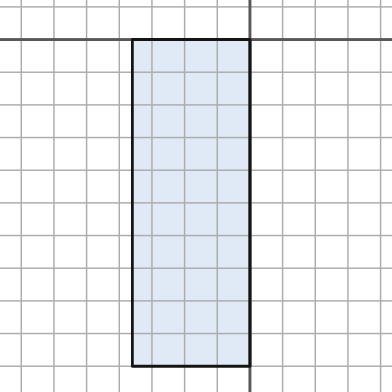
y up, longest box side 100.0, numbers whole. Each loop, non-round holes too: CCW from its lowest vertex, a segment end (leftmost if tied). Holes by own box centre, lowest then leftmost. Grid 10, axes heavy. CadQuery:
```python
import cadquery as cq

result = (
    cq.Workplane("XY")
    .moveTo(-36.0, -100.0)
    .lineTo(0.0, -100.0)
    .lineTo(0.0, 0.0)
    .lineTo(-36.0, 0.0)
    .close()
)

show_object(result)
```